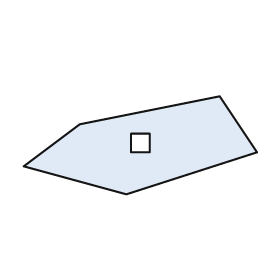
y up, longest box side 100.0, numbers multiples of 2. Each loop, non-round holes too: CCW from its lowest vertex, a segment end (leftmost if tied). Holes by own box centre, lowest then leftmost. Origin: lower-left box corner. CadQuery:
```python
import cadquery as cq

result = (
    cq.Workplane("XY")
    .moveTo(44.0, 0.0)
    .lineTo(100.0, 18.0)
    .lineTo(84.0, 42.0)
    .lineTo(24.0, 30.0)
    .lineTo(0.0, 12.0)
    .close()
    .moveTo(46.0, 18.0)
    .lineTo(54.0, 18.0)
    .lineTo(54.0, 26.0)
    .lineTo(46.0, 26.0)
    .close()
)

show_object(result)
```